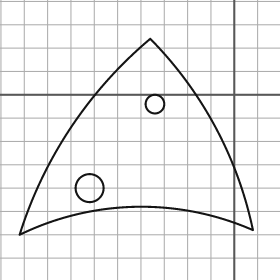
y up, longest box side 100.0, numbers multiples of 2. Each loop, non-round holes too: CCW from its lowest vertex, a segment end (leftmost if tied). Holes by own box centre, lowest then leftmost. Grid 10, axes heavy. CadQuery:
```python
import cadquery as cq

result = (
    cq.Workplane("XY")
    .moveTo(-92.0, -60.0)
    .threePointArc((-42.0, -48.0), (8.0, -58.0))
    .threePointArc((-8.0, -14.0), (-36.0, 24.0))
    .threePointArc((-70.0, -14.0), (-92.0, -60.0))
    .close()
    .moveTo(-62.0, -40.0)
    .circle(6.0)
    .moveTo(-34.0, -4.0)
    .circle(4.0)
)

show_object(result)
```